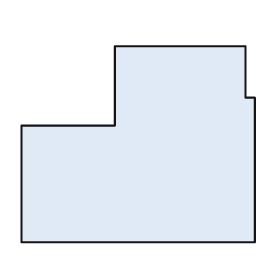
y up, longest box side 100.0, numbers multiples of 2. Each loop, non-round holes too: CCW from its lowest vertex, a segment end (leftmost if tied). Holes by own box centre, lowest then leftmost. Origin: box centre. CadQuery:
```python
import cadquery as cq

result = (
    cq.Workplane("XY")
    .moveTo(-50.0, -42.0)
    .lineTo(50.0, -42.0)
    .lineTo(50.0, 20.0)
    .lineTo(46.0, 20.0)
    .lineTo(46.0, 42.0)
    .lineTo(-10.0, 42.0)
    .lineTo(-10.0, 8.0)
    .lineTo(-50.0, 8.0)
    .close()
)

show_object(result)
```